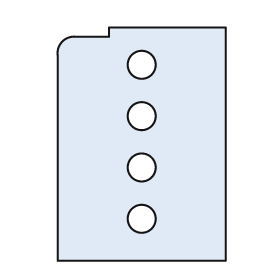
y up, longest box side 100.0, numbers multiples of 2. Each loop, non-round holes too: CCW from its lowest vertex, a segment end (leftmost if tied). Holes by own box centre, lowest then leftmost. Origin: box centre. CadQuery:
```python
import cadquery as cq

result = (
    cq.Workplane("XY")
    .moveTo(-36.0, -50.0)
    .lineTo(36.0, -50.0)
    .lineTo(36.0, 50.0)
    .lineTo(-14.0, 50.0)
    .lineTo(-14.0, 46.0)
    .lineTo(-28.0, 46.0)
    .threePointArc((-34.0, 44.0), (-36.0, 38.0))
    .close()
    .moveTo(0.0, -32.0)
    .circle(6.0)
    .moveTo(0.0, -10.0)
    .circle(6.0)
    .moveTo(0.0, 12.0)
    .circle(6.0)
    .moveTo(0.0, 34.0)
    .circle(6.0)
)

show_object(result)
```